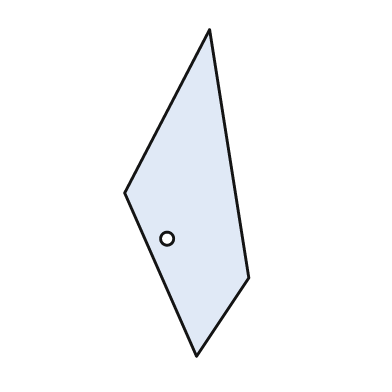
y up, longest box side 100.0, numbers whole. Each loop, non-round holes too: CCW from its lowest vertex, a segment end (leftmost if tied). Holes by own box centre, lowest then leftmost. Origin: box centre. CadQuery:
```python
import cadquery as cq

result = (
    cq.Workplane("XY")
    .moveTo(3.0, -50.0)
    .lineTo(19.0, -26.0)
    .lineTo(7.0, 50.0)
    .lineTo(-19.0, 0.0)
    .close()
    .moveTo(-6.0, -14.0)
    .circle(2.0)
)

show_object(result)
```